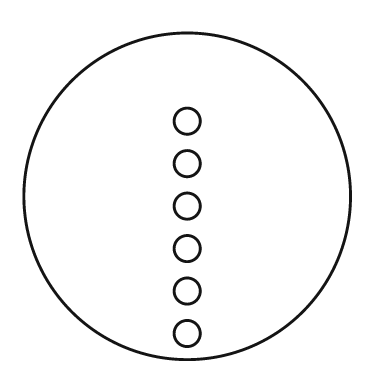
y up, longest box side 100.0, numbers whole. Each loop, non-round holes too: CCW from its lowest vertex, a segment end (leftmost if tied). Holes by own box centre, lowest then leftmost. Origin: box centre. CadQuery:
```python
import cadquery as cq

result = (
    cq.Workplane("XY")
    .moveTo(0.0, 0.0)
    .circle(50.0)
    .moveTo(0.0, -42.0)
    .circle(4.0)
    .moveTo(0.0, -29.0)
    .circle(4.0)
    .moveTo(0.0, -16.0)
    .circle(4.0)
    .moveTo(0.0, -3.0)
    .circle(4.0)
    .moveTo(0.0, 10.0)
    .circle(4.0)
    .moveTo(0.0, 23.0)
    .circle(4.0)
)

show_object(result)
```